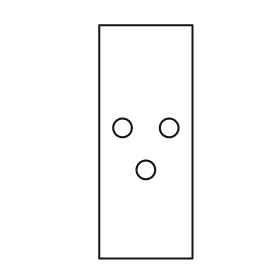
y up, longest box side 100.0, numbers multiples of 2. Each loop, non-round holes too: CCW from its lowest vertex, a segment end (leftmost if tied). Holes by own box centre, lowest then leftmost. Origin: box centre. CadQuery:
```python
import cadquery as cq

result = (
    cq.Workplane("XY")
    .moveTo(-20.0, -50.0)
    .lineTo(20.0, -50.0)
    .lineTo(20.0, 50.0)
    .lineTo(-20.0, 50.0)
    .close()
    .moveTo(0.0, -12.0)
    .circle(4.0)
    .moveTo(-10.0, 6.0)
    .circle(4.0)
    .moveTo(10.0, 6.0)
    .circle(4.0)
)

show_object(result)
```